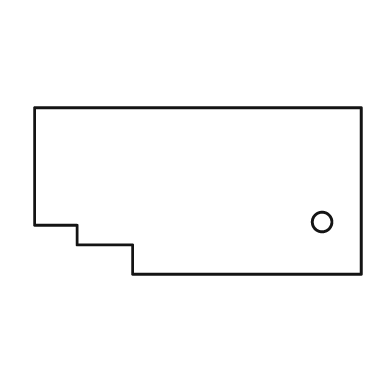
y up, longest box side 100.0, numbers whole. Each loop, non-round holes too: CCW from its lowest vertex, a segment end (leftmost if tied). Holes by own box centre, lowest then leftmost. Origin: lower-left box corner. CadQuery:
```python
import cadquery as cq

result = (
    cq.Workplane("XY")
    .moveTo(30.0, 0.0)
    .lineTo(100.0, 0.0)
    .lineTo(100.0, 51.0)
    .lineTo(0.0, 51.0)
    .lineTo(0.0, 15.0)
    .lineTo(13.0, 15.0)
    .lineTo(13.0, 9.0)
    .lineTo(30.0, 9.0)
    .close()
    .moveTo(88.0, 16.0)
    .circle(3.0)
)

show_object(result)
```